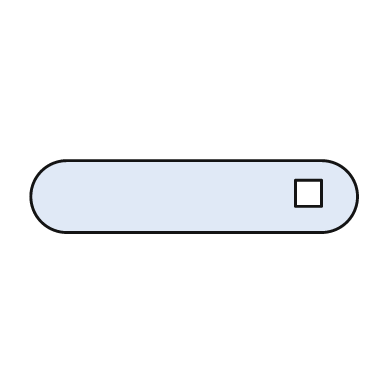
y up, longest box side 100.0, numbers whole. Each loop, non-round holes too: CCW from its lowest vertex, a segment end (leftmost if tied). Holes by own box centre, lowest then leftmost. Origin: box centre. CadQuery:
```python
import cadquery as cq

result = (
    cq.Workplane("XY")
    .moveTo(-39.0, -11.0)
    .lineTo(39.0, -11.0)
    .threePointArc((50.0, 0.0), (39.0, 11.0))
    .lineTo(-39.0, 11.0)
    .threePointArc((-50.0, 0.0), (-39.0, -11.0))
    .close()
    .moveTo(31.0, -3.0)
    .lineTo(39.0, -3.0)
    .lineTo(39.0, 5.0)
    .lineTo(31.0, 5.0)
    .close()
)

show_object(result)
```